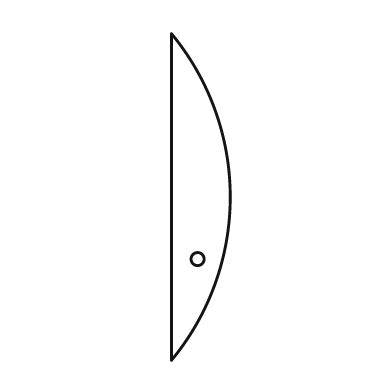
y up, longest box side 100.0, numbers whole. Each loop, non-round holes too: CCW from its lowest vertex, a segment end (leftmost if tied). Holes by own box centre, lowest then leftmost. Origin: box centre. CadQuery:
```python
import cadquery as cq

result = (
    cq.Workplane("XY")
    .moveTo(-9.0, -50.0)
    .threePointArc((9.0, 0.0), (-9.0, 50.0))
    .close()
    .moveTo(-1.0, -19.0)
    .circle(2.0)
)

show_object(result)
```